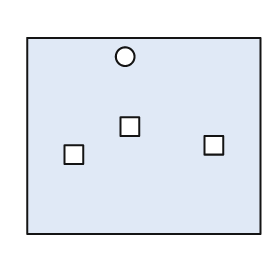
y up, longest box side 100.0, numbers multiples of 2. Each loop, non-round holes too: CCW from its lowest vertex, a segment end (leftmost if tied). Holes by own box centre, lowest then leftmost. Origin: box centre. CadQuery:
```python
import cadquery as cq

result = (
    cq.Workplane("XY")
    .moveTo(-50.0, -42.0)
    .lineTo(50.0, -42.0)
    .lineTo(50.0, 42.0)
    .lineTo(-50.0, 42.0)
    .close()
    .moveTo(-34.0, -12.0)
    .lineTo(-26.0, -12.0)
    .lineTo(-26.0, -4.0)
    .lineTo(-34.0, -4.0)
    .close()
    .moveTo(26.0, -8.0)
    .lineTo(34.0, -8.0)
    .lineTo(34.0, 0.0)
    .lineTo(26.0, 0.0)
    .close()
    .moveTo(-10.0, 0.0)
    .lineTo(-2.0, 0.0)
    .lineTo(-2.0, 8.0)
    .lineTo(-10.0, 8.0)
    .close()
    .moveTo(-8.0, 34.0)
    .circle(4.0)
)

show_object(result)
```